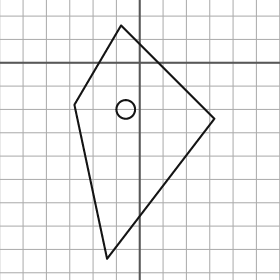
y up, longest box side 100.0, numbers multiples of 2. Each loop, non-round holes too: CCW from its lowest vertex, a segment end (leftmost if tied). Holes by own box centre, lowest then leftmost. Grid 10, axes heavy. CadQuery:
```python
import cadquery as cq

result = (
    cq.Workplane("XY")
    .moveTo(-14.0, -84.0)
    .lineTo(32.0, -24.0)
    .lineTo(-8.0, 16.0)
    .lineTo(-28.0, -18.0)
    .close()
    .moveTo(-6.0, -20.0)
    .circle(4.0)
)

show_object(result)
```